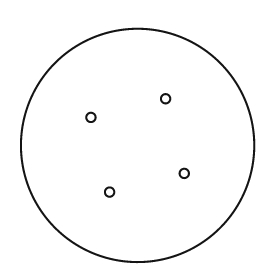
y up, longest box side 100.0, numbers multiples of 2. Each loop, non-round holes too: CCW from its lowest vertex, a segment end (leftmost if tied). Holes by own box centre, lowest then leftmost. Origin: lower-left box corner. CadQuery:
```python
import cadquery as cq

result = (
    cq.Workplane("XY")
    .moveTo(50.0, 50.0)
    .circle(50.0)
    .moveTo(38.0, 30.0)
    .circle(2.0)
    .moveTo(70.0, 38.0)
    .circle(2.0)
    .moveTo(30.0, 62.0)
    .circle(2.0)
    .moveTo(62.0, 70.0)
    .circle(2.0)
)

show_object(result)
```